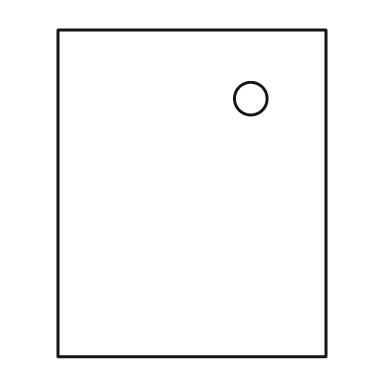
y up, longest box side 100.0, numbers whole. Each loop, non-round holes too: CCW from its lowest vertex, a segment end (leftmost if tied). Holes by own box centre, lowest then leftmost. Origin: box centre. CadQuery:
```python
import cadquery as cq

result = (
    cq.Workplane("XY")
    .moveTo(-41.0, -50.0)
    .lineTo(41.0, -50.0)
    .lineTo(41.0, 50.0)
    .lineTo(-41.0, 50.0)
    .close()
    .moveTo(18.0, 29.0)
    .circle(5.0)
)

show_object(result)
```